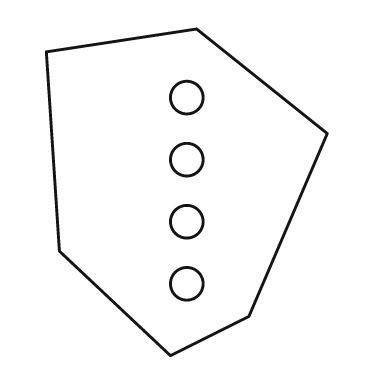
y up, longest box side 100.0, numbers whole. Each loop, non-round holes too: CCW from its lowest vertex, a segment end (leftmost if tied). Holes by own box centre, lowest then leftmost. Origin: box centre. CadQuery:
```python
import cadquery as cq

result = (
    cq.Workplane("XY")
    .moveTo(-5.0, -50.0)
    .lineTo(19.0, -38.0)
    .lineTo(43.0, 18.0)
    .lineTo(3.0, 50.0)
    .lineTo(-43.0, 43.0)
    .lineTo(-39.0, -18.0)
    .close()
    .moveTo(0.0, -28.0)
    .circle(5.0)
    .moveTo(0.0, -9.0)
    .circle(5.0)
    .moveTo(0.0, 10.0)
    .circle(5.0)
    .moveTo(0.0, 29.0)
    .circle(5.0)
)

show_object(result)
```